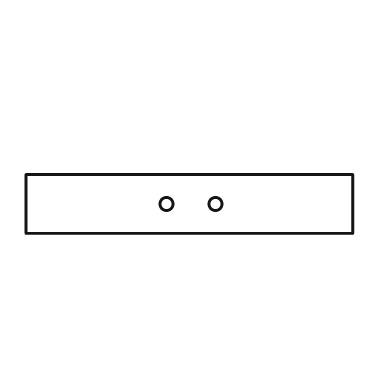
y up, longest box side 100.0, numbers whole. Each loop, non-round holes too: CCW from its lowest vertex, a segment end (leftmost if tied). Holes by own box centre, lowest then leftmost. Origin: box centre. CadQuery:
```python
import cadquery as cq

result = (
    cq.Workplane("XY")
    .moveTo(-50.0, -9.0)
    .lineTo(50.0, -9.0)
    .lineTo(50.0, 9.0)
    .lineTo(-50.0, 9.0)
    .close()
    .moveTo(-7.0, 0.0)
    .circle(2.0)
    .moveTo(8.0, 0.0)
    .circle(2.0)
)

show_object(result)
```